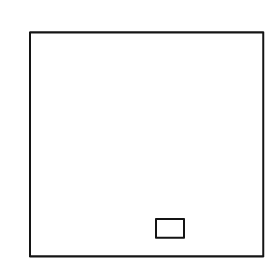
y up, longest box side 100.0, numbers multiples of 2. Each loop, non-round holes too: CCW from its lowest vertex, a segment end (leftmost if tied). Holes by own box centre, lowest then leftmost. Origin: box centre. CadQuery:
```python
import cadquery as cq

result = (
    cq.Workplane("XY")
    .moveTo(-50.0, -48.0)
    .lineTo(50.0, -48.0)
    .lineTo(50.0, 48.0)
    .lineTo(-50.0, 48.0)
    .close()
    .moveTo(4.0, -40.0)
    .lineTo(16.0, -40.0)
    .lineTo(16.0, -32.0)
    .lineTo(4.0, -32.0)
    .close()
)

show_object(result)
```